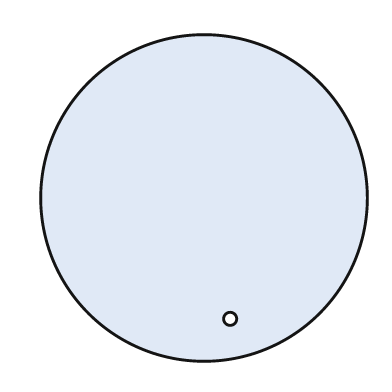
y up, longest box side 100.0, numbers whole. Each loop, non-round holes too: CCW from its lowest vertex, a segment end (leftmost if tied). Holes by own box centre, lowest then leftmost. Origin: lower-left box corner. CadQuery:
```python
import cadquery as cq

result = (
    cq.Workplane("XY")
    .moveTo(50.0, 50.0)
    .circle(50.0)
    .moveTo(58.0, 13.0)
    .circle(2.0)
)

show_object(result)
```